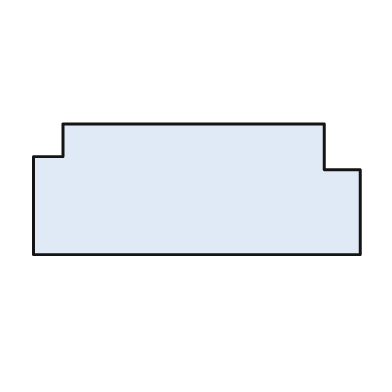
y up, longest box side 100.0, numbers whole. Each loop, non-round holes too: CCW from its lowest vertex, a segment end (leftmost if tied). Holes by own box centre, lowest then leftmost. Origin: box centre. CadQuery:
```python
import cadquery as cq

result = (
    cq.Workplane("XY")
    .moveTo(-50.0, -20.0)
    .lineTo(50.0, -20.0)
    .lineTo(50.0, 6.0)
    .lineTo(39.0, 6.0)
    .lineTo(39.0, 20.0)
    .lineTo(-41.0, 20.0)
    .lineTo(-41.0, 10.0)
    .lineTo(-50.0, 10.0)
    .close()
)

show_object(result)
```